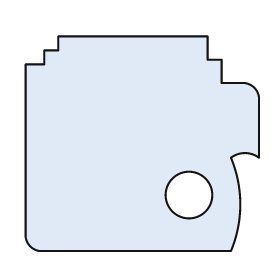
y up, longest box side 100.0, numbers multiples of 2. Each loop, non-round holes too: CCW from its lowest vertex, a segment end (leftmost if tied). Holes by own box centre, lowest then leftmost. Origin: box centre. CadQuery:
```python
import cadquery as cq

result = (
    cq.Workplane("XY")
    .moveTo(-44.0, -46.0)
    .lineTo(38.0, -46.0)
    .threePointArc((42.0, -26.0), (38.0, -6.0))
    .threePointArc((44.0, -4.0), (50.0, -6.0))
    .lineTo(50.0, 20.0)
    .threePointArc((48.0, 24.0), (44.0, 26.0))
    .lineTo(34.0, 26.0)
    .lineTo(34.0, 36.0)
    .lineTo(28.0, 36.0)
    .lineTo(28.0, 46.0)
    .lineTo(-36.0, 46.0)
    .lineTo(-36.0, 40.0)
    .lineTo(-42.0, 40.0)
    .lineTo(-42.0, 34.0)
    .lineTo(-50.0, 34.0)
    .lineTo(-50.0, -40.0)
    .threePointArc((-48.0, -44.0), (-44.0, -46.0))
    .close()
    .moveTo(20.0, -22.0)
    .circle(10.0)
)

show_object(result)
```